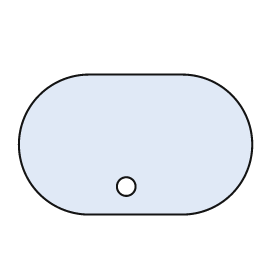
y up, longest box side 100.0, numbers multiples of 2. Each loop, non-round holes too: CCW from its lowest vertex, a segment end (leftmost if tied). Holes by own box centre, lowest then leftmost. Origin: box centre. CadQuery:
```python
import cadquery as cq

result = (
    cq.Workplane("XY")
    .moveTo(-20.0, -30.0)
    .lineTo(20.0, -30.0)
    .threePointArc((50.0, 0.0), (20.0, 30.0))
    .lineTo(-20.0, 30.0)
    .threePointArc((-50.0, 0.0), (-20.0, -30.0))
    .close()
    .moveTo(-4.0, -18.0)
    .circle(4.0)
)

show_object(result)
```